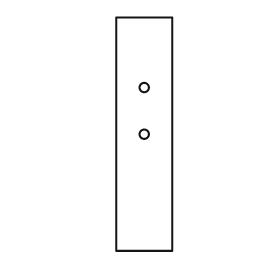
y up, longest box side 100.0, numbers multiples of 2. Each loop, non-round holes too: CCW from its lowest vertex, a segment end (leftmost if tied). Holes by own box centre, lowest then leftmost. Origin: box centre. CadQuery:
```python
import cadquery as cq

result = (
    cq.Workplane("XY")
    .moveTo(-12.0, -50.0)
    .lineTo(12.0, -50.0)
    .lineTo(12.0, 50.0)
    .lineTo(-12.0, 50.0)
    .close()
    .moveTo(0.0, 0.0)
    .circle(2.0)
    .moveTo(0.0, 20.0)
    .circle(2.0)
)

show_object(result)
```